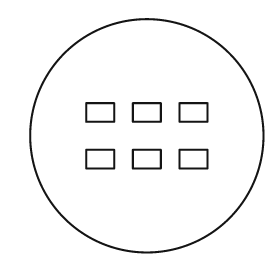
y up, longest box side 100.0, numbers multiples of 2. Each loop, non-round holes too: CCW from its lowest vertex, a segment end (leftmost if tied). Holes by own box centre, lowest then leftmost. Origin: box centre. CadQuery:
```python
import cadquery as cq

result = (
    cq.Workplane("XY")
    .moveTo(0.0, 0.0)
    .circle(50.0)
    .moveTo(-26.0, -14.0)
    .lineTo(-14.0, -14.0)
    .lineTo(-14.0, -6.0)
    .lineTo(-26.0, -6.0)
    .close()
    .moveTo(-6.0, -14.0)
    .lineTo(6.0, -14.0)
    .lineTo(6.0, -6.0)
    .lineTo(-6.0, -6.0)
    .close()
    .moveTo(14.0, -14.0)
    .lineTo(26.0, -14.0)
    .lineTo(26.0, -6.0)
    .lineTo(14.0, -6.0)
    .close()
    .moveTo(-26.0, 6.0)
    .lineTo(-14.0, 6.0)
    .lineTo(-14.0, 14.0)
    .lineTo(-26.0, 14.0)
    .close()
    .moveTo(-6.0, 6.0)
    .lineTo(6.0, 6.0)
    .lineTo(6.0, 14.0)
    .lineTo(-6.0, 14.0)
    .close()
    .moveTo(14.0, 6.0)
    .lineTo(26.0, 6.0)
    .lineTo(26.0, 14.0)
    .lineTo(14.0, 14.0)
    .close()
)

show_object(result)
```